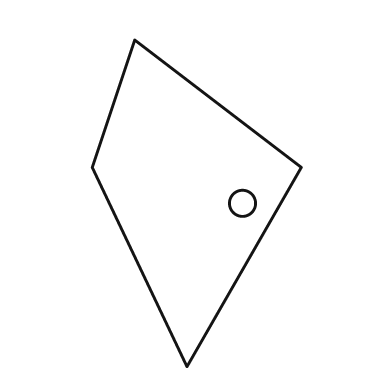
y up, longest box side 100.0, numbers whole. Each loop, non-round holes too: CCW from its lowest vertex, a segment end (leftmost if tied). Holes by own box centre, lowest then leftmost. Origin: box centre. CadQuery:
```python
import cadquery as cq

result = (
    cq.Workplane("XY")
    .moveTo(-3.0, -50.0)
    .lineTo(32.0, 11.0)
    .lineTo(-19.0, 50.0)
    .lineTo(-32.0, 11.0)
    .close()
    .moveTo(14.0, 0.0)
    .circle(4.0)
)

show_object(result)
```